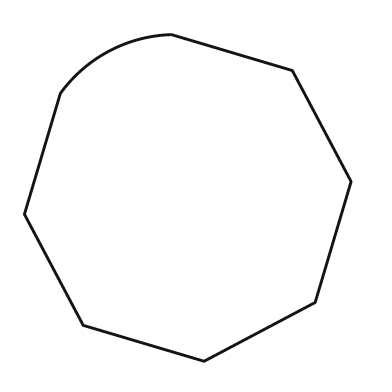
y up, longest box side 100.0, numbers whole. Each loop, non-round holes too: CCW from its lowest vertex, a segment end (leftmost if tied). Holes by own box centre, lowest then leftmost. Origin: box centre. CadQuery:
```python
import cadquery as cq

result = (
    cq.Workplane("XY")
    .moveTo(5.0, -50.0)
    .lineTo(39.0, -32.0)
    .lineTo(50.0, 5.0)
    .lineTo(32.0, 39.0)
    .lineTo(-5.0, 50.0)
    .threePointArc((-24.0, 45.0), (-39.0, 32.0))
    .lineTo(-50.0, -5.0)
    .lineTo(-32.0, -39.0)
    .close()
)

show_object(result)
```